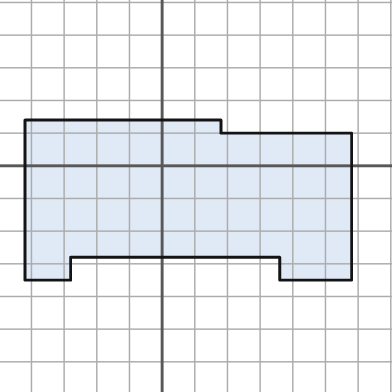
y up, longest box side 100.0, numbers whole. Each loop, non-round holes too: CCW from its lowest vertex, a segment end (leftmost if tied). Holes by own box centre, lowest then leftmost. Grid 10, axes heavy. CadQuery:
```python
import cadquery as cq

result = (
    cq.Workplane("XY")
    .moveTo(-42.0, -35.0)
    .lineTo(-28.0, -35.0)
    .lineTo(-28.0, -28.0)
    .lineTo(36.0, -28.0)
    .lineTo(36.0, -35.0)
    .lineTo(58.0, -35.0)
    .lineTo(58.0, 10.0)
    .lineTo(18.0, 10.0)
    .lineTo(18.0, 14.0)
    .lineTo(-42.0, 14.0)
    .close()
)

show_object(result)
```